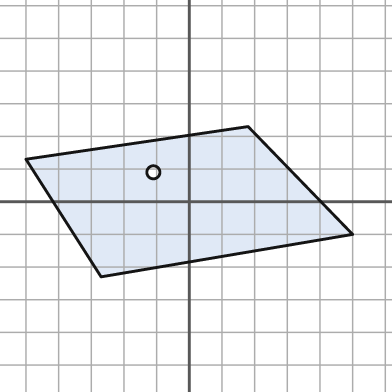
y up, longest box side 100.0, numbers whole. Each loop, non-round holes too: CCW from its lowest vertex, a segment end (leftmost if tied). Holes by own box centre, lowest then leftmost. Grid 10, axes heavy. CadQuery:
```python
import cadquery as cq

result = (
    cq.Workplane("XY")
    .moveTo(-27.0, -23.0)
    .lineTo(50.0, -10.0)
    .lineTo(18.0, 23.0)
    .lineTo(-50.0, 13.0)
    .close()
    .moveTo(-11.0, 9.0)
    .circle(2.0)
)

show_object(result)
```